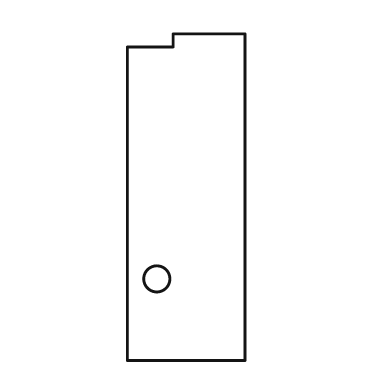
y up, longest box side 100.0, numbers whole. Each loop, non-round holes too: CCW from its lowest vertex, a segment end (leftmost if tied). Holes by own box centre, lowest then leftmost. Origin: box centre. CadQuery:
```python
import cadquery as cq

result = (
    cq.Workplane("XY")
    .moveTo(-18.0, -50.0)
    .lineTo(18.0, -50.0)
    .lineTo(18.0, 50.0)
    .lineTo(-4.0, 50.0)
    .lineTo(-4.0, 46.0)
    .lineTo(-18.0, 46.0)
    .close()
    .moveTo(-9.0, -25.0)
    .circle(4.0)
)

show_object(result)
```